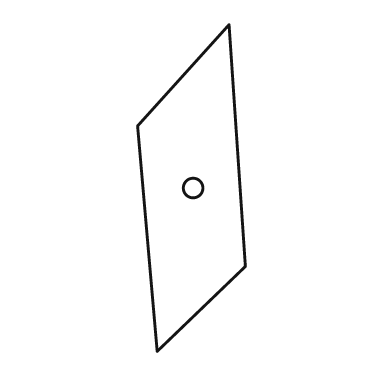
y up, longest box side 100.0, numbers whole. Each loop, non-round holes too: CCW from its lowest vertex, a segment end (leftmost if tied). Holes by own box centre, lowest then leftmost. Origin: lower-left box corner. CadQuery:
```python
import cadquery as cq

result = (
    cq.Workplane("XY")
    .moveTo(6.0, 0.0)
    .lineTo(33.0, 26.0)
    .lineTo(28.0, 100.0)
    .lineTo(0.0, 69.0)
    .close()
    .moveTo(17.0, 50.0)
    .circle(3.0)
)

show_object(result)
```